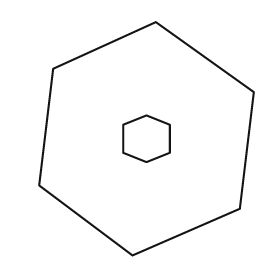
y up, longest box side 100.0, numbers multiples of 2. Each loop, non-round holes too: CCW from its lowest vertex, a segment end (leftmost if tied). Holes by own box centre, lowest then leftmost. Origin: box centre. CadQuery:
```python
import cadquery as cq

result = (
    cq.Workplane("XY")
    .moveTo(-6.0, -50.0)
    .lineTo(40.0, -30.0)
    .lineTo(46.0, 20.0)
    .lineTo(4.0, 50.0)
    .lineTo(-40.0, 30.0)
    .lineTo(-46.0, -20.0)
    .close()
    .moveTo(0.0, -10.0)
    .lineTo(10.0, -6.0)
    .lineTo(10.0, 6.0)
    .lineTo(0.0, 10.0)
    .lineTo(-10.0, 6.0)
    .lineTo(-10.0, -6.0)
    .close()
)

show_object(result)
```